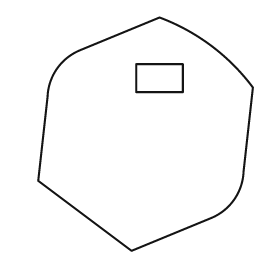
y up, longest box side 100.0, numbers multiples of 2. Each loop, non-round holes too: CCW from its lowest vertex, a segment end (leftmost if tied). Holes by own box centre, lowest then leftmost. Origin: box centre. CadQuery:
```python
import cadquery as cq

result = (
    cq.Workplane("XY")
    .moveTo(-6.0, -50.0)
    .lineTo(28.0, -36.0)
    .threePointArc((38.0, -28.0), (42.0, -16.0))
    .lineTo(46.0, 20.0)
    .threePointArc((28.0, 38.0), (6.0, 50.0))
    .lineTo(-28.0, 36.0)
    .threePointArc((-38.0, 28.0), (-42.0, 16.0))
    .lineTo(-46.0, -20.0)
    .close()
    .moveTo(-4.0, 18.0)
    .lineTo(16.0, 18.0)
    .lineTo(16.0, 30.0)
    .lineTo(-4.0, 30.0)
    .close()
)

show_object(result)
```